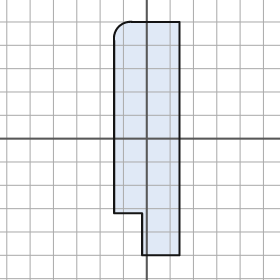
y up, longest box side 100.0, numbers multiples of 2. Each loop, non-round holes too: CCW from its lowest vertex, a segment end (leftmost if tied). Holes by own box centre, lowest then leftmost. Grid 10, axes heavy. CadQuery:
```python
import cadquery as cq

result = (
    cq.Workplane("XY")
    .moveTo(-2.0, -50.0)
    .lineTo(14.0, -50.0)
    .lineTo(14.0, 50.0)
    .lineTo(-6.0, 50.0)
    .threePointArc((-12.0, 48.0), (-14.0, 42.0))
    .lineTo(-14.0, -32.0)
    .lineTo(-2.0, -32.0)
    .close()
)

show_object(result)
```